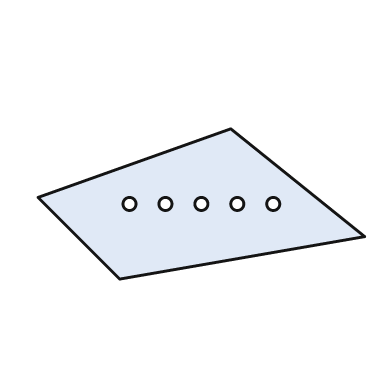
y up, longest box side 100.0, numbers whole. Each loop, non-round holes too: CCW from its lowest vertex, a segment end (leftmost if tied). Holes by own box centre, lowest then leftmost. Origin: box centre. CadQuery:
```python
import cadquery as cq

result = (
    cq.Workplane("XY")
    .moveTo(-25.0, -23.0)
    .lineTo(50.0, -10.0)
    .lineTo(9.0, 23.0)
    .lineTo(-50.0, 2.0)
    .close()
    .moveTo(-22.0, 0.0)
    .circle(2.0)
    .moveTo(-11.0, 0.0)
    .circle(2.0)
    .moveTo(0.0, 0.0)
    .circle(2.0)
    .moveTo(11.0, 0.0)
    .circle(2.0)
    .moveTo(22.0, 0.0)
    .circle(2.0)
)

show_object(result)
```